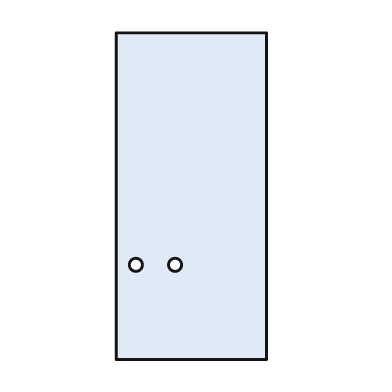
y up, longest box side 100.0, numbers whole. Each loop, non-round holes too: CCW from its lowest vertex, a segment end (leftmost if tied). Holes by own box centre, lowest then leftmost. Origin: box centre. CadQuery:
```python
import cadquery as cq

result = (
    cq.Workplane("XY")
    .moveTo(-23.0, -50.0)
    .lineTo(23.0, -50.0)
    .lineTo(23.0, 50.0)
    .lineTo(-23.0, 50.0)
    .close()
    .moveTo(-17.0, -21.0)
    .circle(2.0)
    .moveTo(-5.0, -21.0)
    .circle(2.0)
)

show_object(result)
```